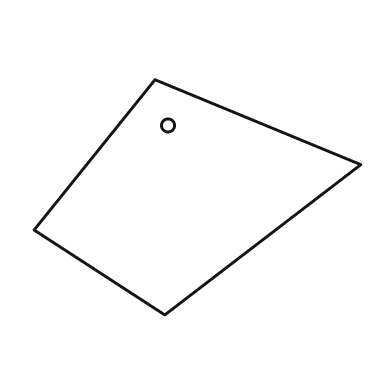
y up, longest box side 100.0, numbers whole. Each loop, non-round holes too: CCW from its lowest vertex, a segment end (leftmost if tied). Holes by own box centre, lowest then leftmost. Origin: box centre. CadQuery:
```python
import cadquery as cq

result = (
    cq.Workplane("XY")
    .moveTo(-10.0, -36.0)
    .lineTo(50.0, 10.0)
    .lineTo(-13.0, 36.0)
    .lineTo(-50.0, -10.0)
    .close()
    .moveTo(-9.0, 22.0)
    .circle(2.0)
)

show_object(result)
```